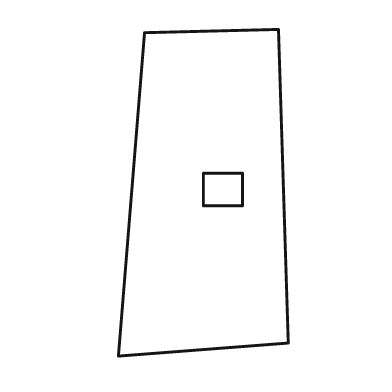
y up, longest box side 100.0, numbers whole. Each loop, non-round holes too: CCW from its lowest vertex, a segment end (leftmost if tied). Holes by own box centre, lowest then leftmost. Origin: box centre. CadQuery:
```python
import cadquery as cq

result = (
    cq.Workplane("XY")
    .moveTo(-26.0, -50.0)
    .lineTo(26.0, -46.0)
    .lineTo(23.0, 50.0)
    .lineTo(-18.0, 49.0)
    .close()
    .moveTo(0.0, -4.0)
    .lineTo(12.0, -4.0)
    .lineTo(12.0, 6.0)
    .lineTo(0.0, 6.0)
    .close()
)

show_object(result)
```